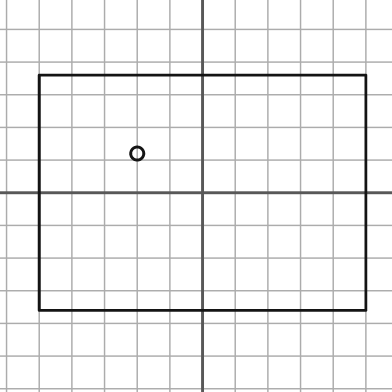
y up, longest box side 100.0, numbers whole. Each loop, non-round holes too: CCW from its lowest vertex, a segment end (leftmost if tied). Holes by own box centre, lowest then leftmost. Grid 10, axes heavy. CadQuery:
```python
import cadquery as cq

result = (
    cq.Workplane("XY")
    .moveTo(-50.0, -36.0)
    .lineTo(50.0, -36.0)
    .lineTo(50.0, 36.0)
    .lineTo(-50.0, 36.0)
    .close()
    .moveTo(-20.0, 12.0)
    .circle(2.0)
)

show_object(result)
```